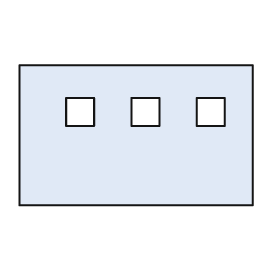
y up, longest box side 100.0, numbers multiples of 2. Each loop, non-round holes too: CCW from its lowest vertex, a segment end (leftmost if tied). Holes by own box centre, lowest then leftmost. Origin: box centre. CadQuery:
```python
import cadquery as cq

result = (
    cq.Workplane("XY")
    .moveTo(-50.0, -30.0)
    .lineTo(50.0, -30.0)
    .lineTo(50.0, 30.0)
    .lineTo(-50.0, 30.0)
    .close()
    .moveTo(-30.0, 4.0)
    .lineTo(-18.0, 4.0)
    .lineTo(-18.0, 16.0)
    .lineTo(-30.0, 16.0)
    .close()
    .moveTo(-2.0, 4.0)
    .lineTo(10.0, 4.0)
    .lineTo(10.0, 16.0)
    .lineTo(-2.0, 16.0)
    .close()
    .moveTo(26.0, 4.0)
    .lineTo(38.0, 4.0)
    .lineTo(38.0, 16.0)
    .lineTo(26.0, 16.0)
    .close()
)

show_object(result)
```